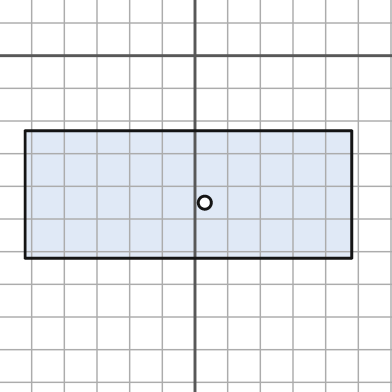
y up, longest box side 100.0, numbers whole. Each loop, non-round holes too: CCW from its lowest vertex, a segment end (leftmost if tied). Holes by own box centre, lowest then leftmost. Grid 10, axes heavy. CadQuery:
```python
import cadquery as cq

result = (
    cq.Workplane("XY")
    .moveTo(-52.0, -62.0)
    .lineTo(48.0, -62.0)
    .lineTo(48.0, -23.0)
    .lineTo(-52.0, -23.0)
    .close()
    .moveTo(3.0, -45.0)
    .circle(2.0)
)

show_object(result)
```